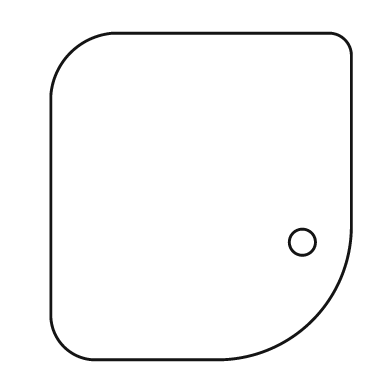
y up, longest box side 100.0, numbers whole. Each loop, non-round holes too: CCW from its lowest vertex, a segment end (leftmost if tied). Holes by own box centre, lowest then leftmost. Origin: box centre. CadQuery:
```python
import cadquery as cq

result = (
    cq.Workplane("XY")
    .moveTo(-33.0, -50.0)
    .lineTo(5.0, -50.0)
    .threePointArc((34.0, -38.0), (46.0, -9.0))
    .lineTo(46.0, 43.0)
    .threePointArc((44.0, 48.0), (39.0, 50.0))
    .lineTo(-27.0, 50.0)
    .threePointArc((-40.0, 44.0), (-46.0, 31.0))
    .lineTo(-46.0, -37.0)
    .threePointArc((-42.0, -46.0), (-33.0, -50.0))
    .close()
    .moveTo(31.0, -14.0)
    .circle(4.0)
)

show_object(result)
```